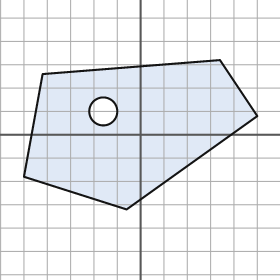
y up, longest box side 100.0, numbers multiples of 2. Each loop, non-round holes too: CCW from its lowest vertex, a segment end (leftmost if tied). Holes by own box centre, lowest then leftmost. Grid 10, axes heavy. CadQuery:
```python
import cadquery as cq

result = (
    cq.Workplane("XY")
    .moveTo(-6.0, -32.0)
    .lineTo(50.0, 8.0)
    .lineTo(34.0, 32.0)
    .lineTo(-42.0, 26.0)
    .lineTo(-50.0, -18.0)
    .close()
    .moveTo(-16.0, 10.0)
    .circle(6.0)
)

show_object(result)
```